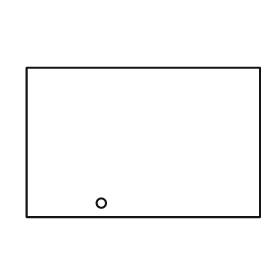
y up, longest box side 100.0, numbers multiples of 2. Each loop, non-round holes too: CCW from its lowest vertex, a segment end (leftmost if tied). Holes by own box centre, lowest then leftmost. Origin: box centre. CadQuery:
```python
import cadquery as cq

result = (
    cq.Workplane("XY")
    .moveTo(-50.0, -32.0)
    .lineTo(50.0, -32.0)
    .lineTo(50.0, 32.0)
    .lineTo(-50.0, 32.0)
    .close()
    .moveTo(-18.0, -26.0)
    .circle(2.0)
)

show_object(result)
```